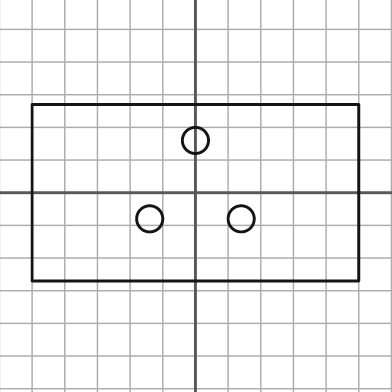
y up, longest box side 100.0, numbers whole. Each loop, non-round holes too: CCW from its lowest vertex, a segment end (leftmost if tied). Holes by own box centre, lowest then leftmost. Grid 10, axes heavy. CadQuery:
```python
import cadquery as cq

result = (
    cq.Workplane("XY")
    .moveTo(-50.0, -27.0)
    .lineTo(50.0, -27.0)
    .lineTo(50.0, 27.0)
    .lineTo(-50.0, 27.0)
    .close()
    .moveTo(-14.0, -8.0)
    .circle(4.0)
    .moveTo(14.0, -8.0)
    .circle(4.0)
    .moveTo(0.0, 16.0)
    .circle(4.0)
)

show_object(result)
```